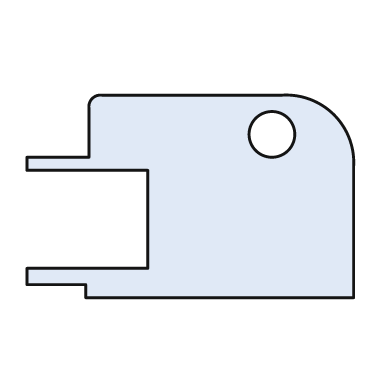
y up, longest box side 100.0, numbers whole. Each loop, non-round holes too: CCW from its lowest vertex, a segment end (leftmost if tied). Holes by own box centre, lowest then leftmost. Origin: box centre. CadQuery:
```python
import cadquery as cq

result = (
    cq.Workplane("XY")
    .moveTo(-32.0, -31.0)
    .lineTo(50.0, -31.0)
    .lineTo(50.0, 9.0)
    .threePointArc((44.0, 25.0), (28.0, 31.0))
    .lineTo(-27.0, 31.0)
    .threePointArc((-30.0, 30.0), (-31.0, 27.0))
    .lineTo(-31.0, 12.0)
    .lineTo(-50.0, 12.0)
    .lineTo(-50.0, 8.0)
    .lineTo(-13.0, 8.0)
    .lineTo(-13.0, -22.0)
    .lineTo(-50.0, -22.0)
    .lineTo(-50.0, -27.0)
    .lineTo(-32.0, -27.0)
    .close()
    .moveTo(25.0, 19.0)
    .circle(7.0)
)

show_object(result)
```